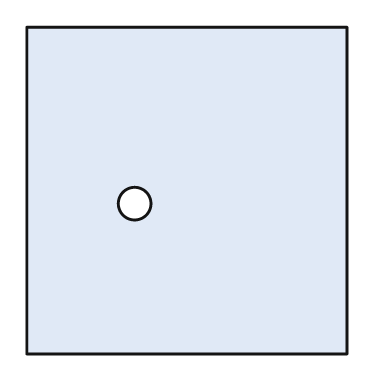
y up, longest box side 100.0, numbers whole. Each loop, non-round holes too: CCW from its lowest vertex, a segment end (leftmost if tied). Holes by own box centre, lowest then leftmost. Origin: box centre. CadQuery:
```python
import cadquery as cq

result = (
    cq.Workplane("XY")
    .moveTo(-49.0, -50.0)
    .lineTo(49.0, -50.0)
    .lineTo(49.0, 50.0)
    .lineTo(-49.0, 50.0)
    .close()
    .moveTo(-16.0, -4.0)
    .circle(5.0)
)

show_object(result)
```